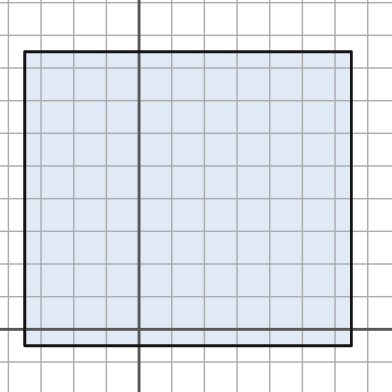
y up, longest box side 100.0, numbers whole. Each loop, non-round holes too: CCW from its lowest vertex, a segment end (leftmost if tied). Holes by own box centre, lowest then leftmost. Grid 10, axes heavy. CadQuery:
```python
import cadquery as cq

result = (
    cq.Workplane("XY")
    .moveTo(-35.0, -5.0)
    .lineTo(65.0, -5.0)
    .lineTo(65.0, 85.0)
    .lineTo(-35.0, 85.0)
    .close()
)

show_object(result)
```